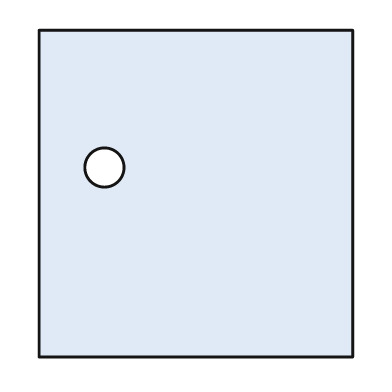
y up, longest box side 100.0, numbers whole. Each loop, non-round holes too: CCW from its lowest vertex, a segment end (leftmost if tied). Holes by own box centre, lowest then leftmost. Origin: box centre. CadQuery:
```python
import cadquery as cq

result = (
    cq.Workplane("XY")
    .moveTo(-48.0, -50.0)
    .lineTo(48.0, -50.0)
    .lineTo(48.0, 50.0)
    .lineTo(-48.0, 50.0)
    .close()
    .moveTo(-28.0, 8.0)
    .circle(6.0)
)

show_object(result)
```